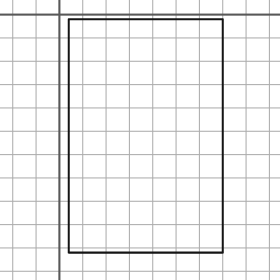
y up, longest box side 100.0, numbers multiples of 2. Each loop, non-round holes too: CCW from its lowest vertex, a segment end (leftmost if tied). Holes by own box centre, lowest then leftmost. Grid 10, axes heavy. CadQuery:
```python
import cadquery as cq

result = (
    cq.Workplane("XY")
    .moveTo(4.0, -102.0)
    .lineTo(70.0, -102.0)
    .lineTo(70.0, -2.0)
    .lineTo(4.0, -2.0)
    .close()
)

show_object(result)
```